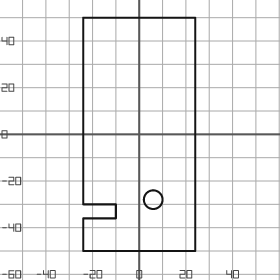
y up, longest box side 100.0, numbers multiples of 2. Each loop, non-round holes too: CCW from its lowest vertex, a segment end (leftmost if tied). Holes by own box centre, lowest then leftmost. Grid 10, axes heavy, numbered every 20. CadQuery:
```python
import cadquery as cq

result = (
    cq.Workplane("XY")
    .moveTo(-24.0, -50.0)
    .lineTo(24.0, -50.0)
    .lineTo(24.0, 50.0)
    .lineTo(-24.0, 50.0)
    .lineTo(-24.0, -30.0)
    .lineTo(-10.0, -30.0)
    .lineTo(-10.0, -36.0)
    .lineTo(-24.0, -36.0)
    .close()
    .moveTo(6.0, -28.0)
    .circle(4.0)
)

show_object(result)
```